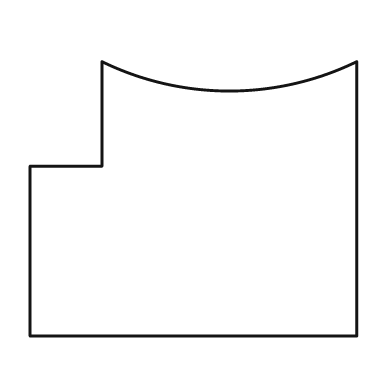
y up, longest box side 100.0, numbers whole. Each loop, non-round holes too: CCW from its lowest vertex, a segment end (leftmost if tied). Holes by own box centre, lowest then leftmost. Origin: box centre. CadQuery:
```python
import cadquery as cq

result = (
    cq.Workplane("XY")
    .moveTo(-50.0, -42.0)
    .lineTo(50.0, -42.0)
    .lineTo(50.0, 42.0)
    .threePointArc((11.0, 33.0), (-28.0, 42.0))
    .lineTo(-28.0, 10.0)
    .lineTo(-50.0, 10.0)
    .close()
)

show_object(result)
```